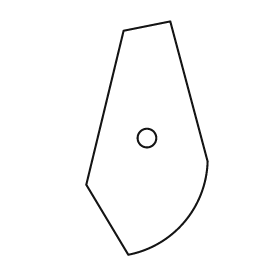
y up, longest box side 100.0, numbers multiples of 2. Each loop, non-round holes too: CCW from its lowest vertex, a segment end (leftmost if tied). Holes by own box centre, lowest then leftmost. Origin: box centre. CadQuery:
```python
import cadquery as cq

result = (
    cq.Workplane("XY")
    .moveTo(-8.0, -50.0)
    .threePointArc((16.0, -36.0), (26.0, -10.0))
    .lineTo(10.0, 50.0)
    .lineTo(-10.0, 46.0)
    .lineTo(-26.0, -20.0)
    .close()
    .moveTo(0.0, 0.0)
    .circle(4.0)
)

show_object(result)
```